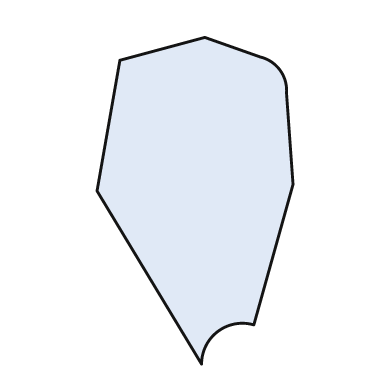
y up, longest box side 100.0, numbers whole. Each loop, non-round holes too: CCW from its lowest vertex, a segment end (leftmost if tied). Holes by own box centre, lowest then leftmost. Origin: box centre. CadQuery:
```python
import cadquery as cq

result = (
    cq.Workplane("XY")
    .moveTo(2.0, -50.0)
    .threePointArc((7.0, -40.0), (18.0, -38.0))
    .lineTo(30.0, 5.0)
    .lineTo(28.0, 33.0)
    .threePointArc((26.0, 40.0), (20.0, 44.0))
    .lineTo(3.0, 50.0)
    .lineTo(-23.0, 43.0)
    .lineTo(-30.0, 3.0)
    .close()
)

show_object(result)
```